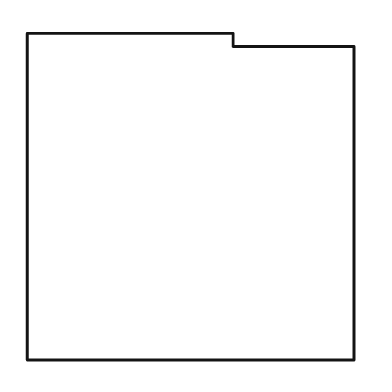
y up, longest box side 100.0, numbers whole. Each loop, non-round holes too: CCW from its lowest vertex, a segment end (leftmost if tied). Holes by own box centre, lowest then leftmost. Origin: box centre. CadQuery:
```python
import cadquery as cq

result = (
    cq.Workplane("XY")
    .moveTo(-50.0, -50.0)
    .lineTo(50.0, -50.0)
    .lineTo(50.0, 46.0)
    .lineTo(13.0, 46.0)
    .lineTo(13.0, 50.0)
    .lineTo(-50.0, 50.0)
    .close()
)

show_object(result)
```